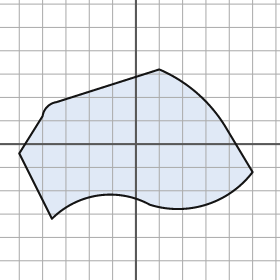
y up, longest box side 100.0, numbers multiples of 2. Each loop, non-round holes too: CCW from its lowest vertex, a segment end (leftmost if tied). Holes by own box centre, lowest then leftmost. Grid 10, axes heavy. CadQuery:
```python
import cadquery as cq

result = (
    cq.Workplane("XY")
    .moveTo(-36.0, -32.0)
    .threePointArc((-16.0, -22.0), (6.0, -26.0))
    .threePointArc((30.0, -26.0), (50.0, -12.0))
    .lineTo(38.0, 8.0)
    .threePointArc((26.0, 22.0), (10.0, 32.0))
    .lineTo(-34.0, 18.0)
    .threePointArc((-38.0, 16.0), (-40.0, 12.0))
    .lineTo(-50.0, -4.0)
    .close()
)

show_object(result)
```